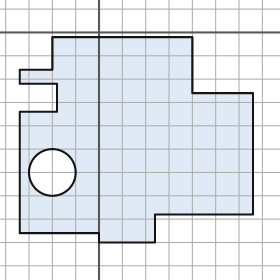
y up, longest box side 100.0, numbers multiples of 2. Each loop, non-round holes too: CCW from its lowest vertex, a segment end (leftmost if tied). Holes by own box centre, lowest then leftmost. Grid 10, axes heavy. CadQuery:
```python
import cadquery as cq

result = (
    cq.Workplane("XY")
    .moveTo(0.0, -90.0)
    .lineTo(24.0, -90.0)
    .lineTo(24.0, -78.0)
    .lineTo(66.0, -78.0)
    .lineTo(66.0, -26.0)
    .lineTo(40.0, -26.0)
    .lineTo(40.0, -2.0)
    .lineTo(-20.0, -2.0)
    .lineTo(-20.0, -16.0)
    .lineTo(-34.0, -16.0)
    .lineTo(-34.0, -22.0)
    .lineTo(-18.0, -22.0)
    .lineTo(-18.0, -34.0)
    .lineTo(-34.0, -34.0)
    .lineTo(-34.0, -86.0)
    .lineTo(0.0, -86.0)
    .close()
    .moveTo(-20.0, -60.0)
    .circle(10.0)
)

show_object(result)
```